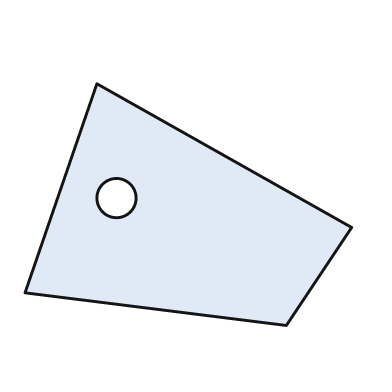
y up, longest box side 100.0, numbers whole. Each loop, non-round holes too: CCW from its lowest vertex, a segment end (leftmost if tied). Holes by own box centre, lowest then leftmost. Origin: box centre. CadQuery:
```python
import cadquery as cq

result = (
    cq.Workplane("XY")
    .moveTo(30.0, -37.0)
    .lineTo(50.0, -7.0)
    .lineTo(-28.0, 37.0)
    .lineTo(-50.0, -27.0)
    .close()
    .moveTo(-22.0, 2.0)
    .circle(6.0)
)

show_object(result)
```